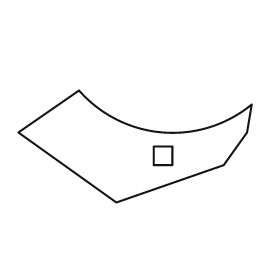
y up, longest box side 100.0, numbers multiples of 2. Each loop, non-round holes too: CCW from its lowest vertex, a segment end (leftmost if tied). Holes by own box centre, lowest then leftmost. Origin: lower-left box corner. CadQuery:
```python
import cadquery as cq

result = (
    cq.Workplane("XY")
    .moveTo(42.0, 0.0)
    .lineTo(88.0, 16.0)
    .lineTo(98.0, 30.0)
    .lineTo(100.0, 42.0)
    .threePointArc((62.0, 30.0), (26.0, 48.0))
    .lineTo(0.0, 30.0)
    .close()
    .moveTo(58.0, 16.0)
    .lineTo(66.0, 16.0)
    .lineTo(66.0, 24.0)
    .lineTo(58.0, 24.0)
    .close()
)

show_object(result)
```